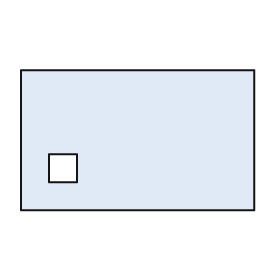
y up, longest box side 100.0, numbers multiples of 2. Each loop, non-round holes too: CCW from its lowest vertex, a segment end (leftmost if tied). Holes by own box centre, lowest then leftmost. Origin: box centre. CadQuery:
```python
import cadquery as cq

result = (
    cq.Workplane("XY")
    .moveTo(-50.0, -30.0)
    .lineTo(50.0, -30.0)
    .lineTo(50.0, 30.0)
    .lineTo(-50.0, 30.0)
    .close()
    .moveTo(-38.0, -18.0)
    .lineTo(-26.0, -18.0)
    .lineTo(-26.0, -6.0)
    .lineTo(-38.0, -6.0)
    .close()
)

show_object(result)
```